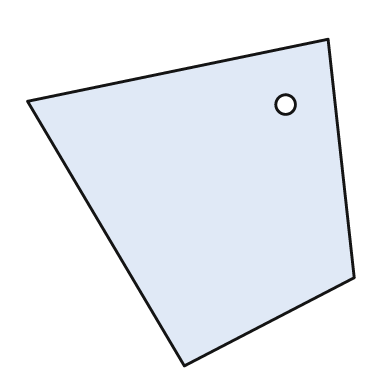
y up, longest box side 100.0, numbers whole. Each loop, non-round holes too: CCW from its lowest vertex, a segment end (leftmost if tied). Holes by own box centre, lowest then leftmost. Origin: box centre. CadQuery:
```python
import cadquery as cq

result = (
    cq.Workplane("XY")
    .moveTo(-2.0, -50.0)
    .lineTo(50.0, -23.0)
    .lineTo(42.0, 50.0)
    .lineTo(-50.0, 31.0)
    .close()
    .moveTo(29.0, 30.0)
    .circle(3.0)
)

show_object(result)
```